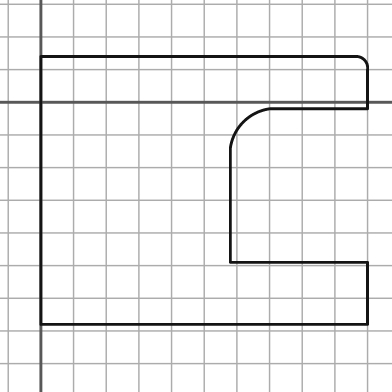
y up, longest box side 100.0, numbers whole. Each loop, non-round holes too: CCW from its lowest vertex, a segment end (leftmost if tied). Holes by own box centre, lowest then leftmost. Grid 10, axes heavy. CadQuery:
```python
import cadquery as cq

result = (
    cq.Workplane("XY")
    .moveTo(0.0, -68.0)
    .lineTo(100.0, -68.0)
    .lineTo(100.0, -49.0)
    .lineTo(58.0, -49.0)
    .lineTo(58.0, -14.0)
    .threePointArc((62.0, -6.0), (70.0, -2.0))
    .lineTo(100.0, -2.0)
    .lineTo(100.0, 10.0)
    .threePointArc((99.0, 13.0), (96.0, 14.0))
    .lineTo(0.0, 14.0)
    .close()
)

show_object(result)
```